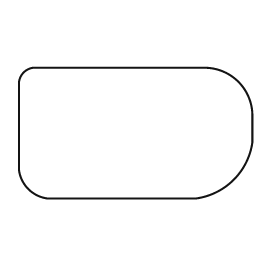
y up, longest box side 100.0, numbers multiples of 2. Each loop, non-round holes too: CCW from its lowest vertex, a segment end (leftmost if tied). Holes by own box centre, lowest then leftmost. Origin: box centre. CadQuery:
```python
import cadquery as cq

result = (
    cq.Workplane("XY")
    .moveTo(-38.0, -28.0)
    .lineTo(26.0, -28.0)
    .threePointArc((42.0, -20.0), (50.0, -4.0))
    .lineTo(50.0, 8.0)
    .threePointArc((44.0, 22.0), (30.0, 28.0))
    .lineTo(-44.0, 28.0)
    .threePointArc((-48.0, 26.0), (-50.0, 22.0))
    .lineTo(-50.0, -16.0)
    .threePointArc((-46.0, -24.0), (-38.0, -28.0))
    .close()
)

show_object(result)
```